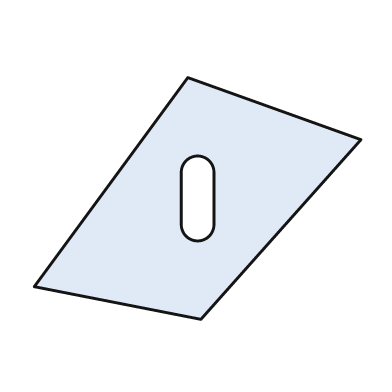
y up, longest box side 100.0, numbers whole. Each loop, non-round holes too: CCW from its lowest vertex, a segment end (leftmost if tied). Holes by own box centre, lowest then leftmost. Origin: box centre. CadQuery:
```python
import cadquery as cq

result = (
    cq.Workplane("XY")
    .moveTo(1.0, -37.0)
    .lineTo(50.0, 18.0)
    .lineTo(-3.0, 37.0)
    .lineTo(-50.0, -27.0)
    .close()
    .moveTo(-5.0, -8.0)
    .threePointArc((0.0, -13.0), (5.0, -8.0))
    .lineTo(5.0, 8.0)
    .threePointArc((0.0, 13.0), (-5.0, 8.0))
    .close()
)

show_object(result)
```